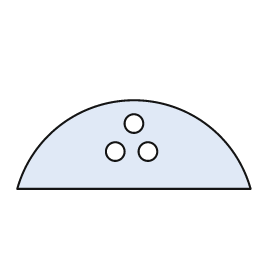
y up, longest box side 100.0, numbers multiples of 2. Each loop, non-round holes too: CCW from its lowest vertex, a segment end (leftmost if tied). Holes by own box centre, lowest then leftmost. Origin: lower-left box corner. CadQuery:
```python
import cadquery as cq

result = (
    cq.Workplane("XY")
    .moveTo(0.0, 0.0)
    .lineTo(100.0, 0.0)
    .threePointArc((50.0, 38.0), (0.0, 0.0))
    .close()
    .moveTo(42.0, 16.0)
    .circle(4.0)
    .moveTo(56.0, 16.0)
    .circle(4.0)
    .moveTo(50.0, 28.0)
    .circle(4.0)
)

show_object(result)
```